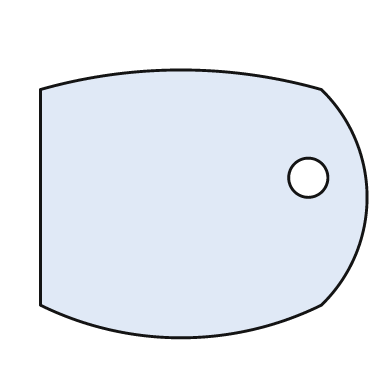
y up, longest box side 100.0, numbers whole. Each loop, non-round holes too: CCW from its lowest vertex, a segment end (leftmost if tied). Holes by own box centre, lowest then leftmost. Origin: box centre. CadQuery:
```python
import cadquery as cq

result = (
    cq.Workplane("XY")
    .moveTo(-50.0, -31.0)
    .threePointArc((-7.0, -41.0), (36.0, -31.0))
    .threePointArc((50.0, 2.0), (36.0, 35.0))
    .threePointArc((-7.0, 41.0), (-50.0, 35.0))
    .close()
    .moveTo(32.0, 8.0)
    .circle(6.0)
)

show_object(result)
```